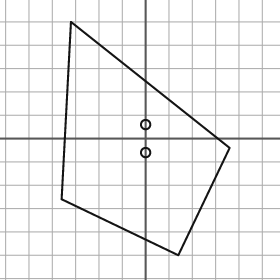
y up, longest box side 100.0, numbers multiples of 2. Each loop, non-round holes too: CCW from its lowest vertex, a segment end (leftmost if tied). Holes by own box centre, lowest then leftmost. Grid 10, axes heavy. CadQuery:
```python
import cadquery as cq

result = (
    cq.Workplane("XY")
    .moveTo(14.0, -50.0)
    .lineTo(36.0, -4.0)
    .lineTo(-32.0, 50.0)
    .lineTo(-36.0, -26.0)
    .close()
    .moveTo(0.0, -6.0)
    .circle(2.0)
    .moveTo(0.0, 6.0)
    .circle(2.0)
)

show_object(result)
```